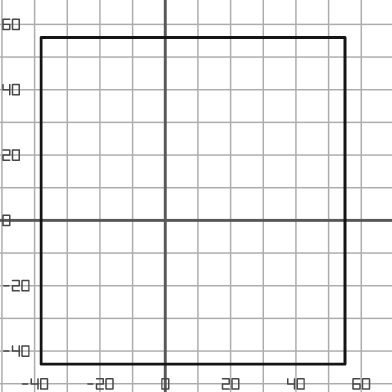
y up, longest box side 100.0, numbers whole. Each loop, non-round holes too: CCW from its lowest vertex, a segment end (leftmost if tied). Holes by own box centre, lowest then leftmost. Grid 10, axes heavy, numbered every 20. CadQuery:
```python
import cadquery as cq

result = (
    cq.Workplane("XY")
    .moveTo(-38.0, -44.0)
    .lineTo(55.0, -44.0)
    .lineTo(55.0, 56.0)
    .lineTo(-38.0, 56.0)
    .close()
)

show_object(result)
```